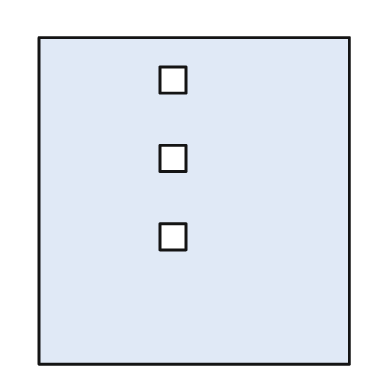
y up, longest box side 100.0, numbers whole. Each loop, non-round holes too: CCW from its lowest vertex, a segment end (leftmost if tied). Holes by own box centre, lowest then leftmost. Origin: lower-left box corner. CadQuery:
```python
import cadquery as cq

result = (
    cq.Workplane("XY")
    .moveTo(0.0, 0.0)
    .lineTo(95.0, 0.0)
    .lineTo(95.0, 100.0)
    .lineTo(0.0, 100.0)
    .close()
    .moveTo(37.0, 35.0)
    .lineTo(45.0, 35.0)
    .lineTo(45.0, 43.0)
    .lineTo(37.0, 43.0)
    .close()
    .moveTo(37.0, 59.0)
    .lineTo(45.0, 59.0)
    .lineTo(45.0, 67.0)
    .lineTo(37.0, 67.0)
    .close()
    .moveTo(37.0, 83.0)
    .lineTo(45.0, 83.0)
    .lineTo(45.0, 91.0)
    .lineTo(37.0, 91.0)
    .close()
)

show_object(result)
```